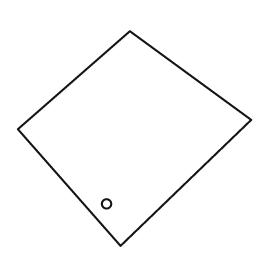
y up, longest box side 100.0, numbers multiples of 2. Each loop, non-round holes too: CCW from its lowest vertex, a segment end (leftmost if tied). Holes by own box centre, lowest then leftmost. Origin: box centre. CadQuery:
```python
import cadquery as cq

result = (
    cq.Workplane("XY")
    .moveTo(-6.0, -46.0)
    .lineTo(50.0, 8.0)
    .lineTo(-2.0, 46.0)
    .lineTo(-50.0, 4.0)
    .close()
    .moveTo(-12.0, -28.0)
    .circle(2.0)
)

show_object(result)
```